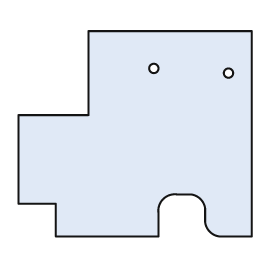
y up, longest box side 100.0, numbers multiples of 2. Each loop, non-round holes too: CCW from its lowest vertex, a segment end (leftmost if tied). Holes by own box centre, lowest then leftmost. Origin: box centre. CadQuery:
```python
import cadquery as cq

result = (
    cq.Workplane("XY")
    .moveTo(-34.0, -44.0)
    .lineTo(10.0, -44.0)
    .lineTo(10.0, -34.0)
    .threePointArc((12.0, -28.0), (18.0, -26.0))
    .lineTo(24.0, -26.0)
    .threePointArc((28.0, -28.0), (30.0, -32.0))
    .lineTo(30.0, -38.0)
    .threePointArc((32.0, -42.0), (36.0, -44.0))
    .lineTo(50.0, -44.0)
    .lineTo(50.0, 44.0)
    .lineTo(-20.0, 44.0)
    .lineTo(-20.0, 8.0)
    .lineTo(-50.0, 8.0)
    .lineTo(-50.0, -30.0)
    .lineTo(-34.0, -30.0)
    .close()
    .moveTo(40.0, 26.0)
    .circle(2.0)
    .moveTo(8.0, 28.0)
    .circle(2.0)
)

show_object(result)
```